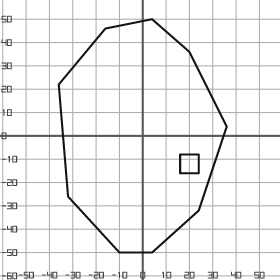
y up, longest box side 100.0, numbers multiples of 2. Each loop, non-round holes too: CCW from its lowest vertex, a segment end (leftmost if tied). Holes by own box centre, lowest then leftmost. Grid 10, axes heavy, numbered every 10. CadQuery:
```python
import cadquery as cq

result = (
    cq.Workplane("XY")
    .moveTo(-10.0, -50.0)
    .lineTo(4.0, -50.0)
    .lineTo(24.0, -32.0)
    .lineTo(36.0, 4.0)
    .lineTo(20.0, 36.0)
    .lineTo(4.0, 50.0)
    .lineTo(-16.0, 46.0)
    .lineTo(-36.0, 22.0)
    .lineTo(-32.0, -26.0)
    .close()
    .moveTo(16.0, -16.0)
    .lineTo(24.0, -16.0)
    .lineTo(24.0, -8.0)
    .lineTo(16.0, -8.0)
    .close()
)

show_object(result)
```